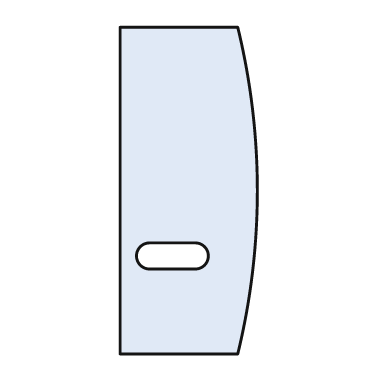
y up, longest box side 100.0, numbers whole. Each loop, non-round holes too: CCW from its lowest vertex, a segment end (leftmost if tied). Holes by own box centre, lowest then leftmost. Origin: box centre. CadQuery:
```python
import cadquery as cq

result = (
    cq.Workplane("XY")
    .moveTo(-21.0, -50.0)
    .lineTo(15.0, -50.0)
    .threePointArc((21.0, 0.0), (15.0, 50.0))
    .lineTo(-21.0, 50.0)
    .close()
    .moveTo(-12.0, -24.0)
    .lineTo(2.0, -24.0)
    .threePointArc((6.0, -20.0), (2.0, -16.0))
    .lineTo(-12.0, -16.0)
    .threePointArc((-16.0, -20.0), (-12.0, -24.0))
    .close()
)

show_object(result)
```